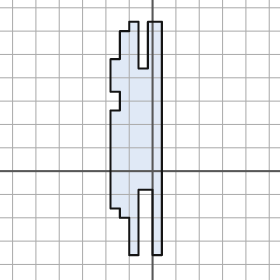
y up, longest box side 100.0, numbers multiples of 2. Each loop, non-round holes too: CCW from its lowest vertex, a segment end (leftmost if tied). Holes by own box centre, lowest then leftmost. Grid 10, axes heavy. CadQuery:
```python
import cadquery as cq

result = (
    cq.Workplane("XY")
    .moveTo(-10.0, -36.0)
    .lineTo(-6.0, -36.0)
    .lineTo(-6.0, -8.0)
    .lineTo(0.0, -8.0)
    .lineTo(0.0, -36.0)
    .lineTo(4.0, -36.0)
    .lineTo(4.0, 64.0)
    .lineTo(-2.0, 64.0)
    .lineTo(-2.0, 44.0)
    .lineTo(-6.0, 44.0)
    .lineTo(-6.0, 64.0)
    .lineTo(-10.0, 64.0)
    .lineTo(-10.0, 60.0)
    .lineTo(-14.0, 60.0)
    .lineTo(-14.0, 48.0)
    .lineTo(-18.0, 48.0)
    .lineTo(-18.0, 34.0)
    .lineTo(-14.0, 34.0)
    .lineTo(-14.0, 26.0)
    .lineTo(-18.0, 26.0)
    .lineTo(-18.0, -16.0)
    .lineTo(-14.0, -16.0)
    .lineTo(-14.0, -20.0)
    .lineTo(-10.0, -20.0)
    .close()
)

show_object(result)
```